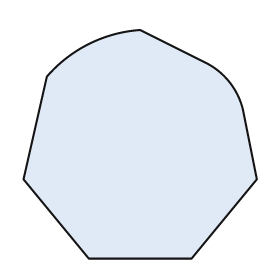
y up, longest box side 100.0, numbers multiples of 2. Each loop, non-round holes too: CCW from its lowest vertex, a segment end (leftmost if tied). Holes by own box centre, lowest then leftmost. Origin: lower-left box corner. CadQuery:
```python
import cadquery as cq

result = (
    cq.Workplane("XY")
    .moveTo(28.0, 0.0)
    .lineTo(72.0, 0.0)
    .lineTo(100.0, 34.0)
    .lineTo(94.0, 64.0)
    .threePointArc((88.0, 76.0), (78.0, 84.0))
    .lineTo(50.0, 98.0)
    .threePointArc((28.0, 92.0), (10.0, 78.0))
    .lineTo(0.0, 34.0)
    .close()
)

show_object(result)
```